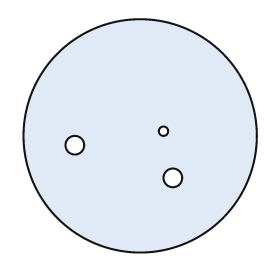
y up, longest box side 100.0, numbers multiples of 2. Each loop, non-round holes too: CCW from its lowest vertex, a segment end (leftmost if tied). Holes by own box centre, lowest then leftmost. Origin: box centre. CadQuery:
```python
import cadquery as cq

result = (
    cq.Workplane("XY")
    .moveTo(0.0, 0.0)
    .circle(50.0)
    .moveTo(14.0, -18.0)
    .circle(4.0)
    .moveTo(-28.0, -4.0)
    .circle(4.0)
    .moveTo(10.0, 2.0)
    .circle(2.0)
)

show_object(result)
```